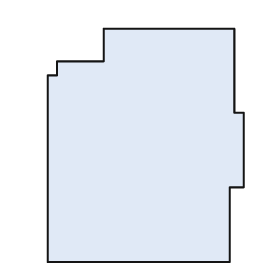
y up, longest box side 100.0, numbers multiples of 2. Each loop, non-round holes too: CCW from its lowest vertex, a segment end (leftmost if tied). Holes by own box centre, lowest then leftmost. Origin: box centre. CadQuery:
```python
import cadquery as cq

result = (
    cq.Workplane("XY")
    .moveTo(-42.0, -50.0)
    .lineTo(36.0, -50.0)
    .lineTo(36.0, -18.0)
    .lineTo(42.0, -18.0)
    .lineTo(42.0, 14.0)
    .lineTo(38.0, 14.0)
    .lineTo(38.0, 50.0)
    .lineTo(-18.0, 50.0)
    .lineTo(-18.0, 36.0)
    .lineTo(-38.0, 36.0)
    .lineTo(-38.0, 30.0)
    .lineTo(-42.0, 30.0)
    .close()
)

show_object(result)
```